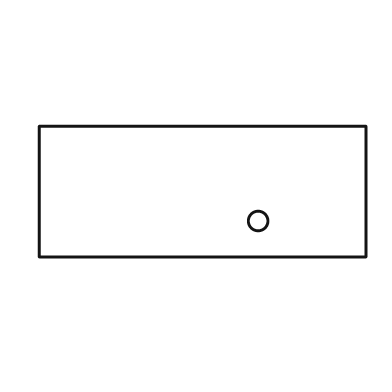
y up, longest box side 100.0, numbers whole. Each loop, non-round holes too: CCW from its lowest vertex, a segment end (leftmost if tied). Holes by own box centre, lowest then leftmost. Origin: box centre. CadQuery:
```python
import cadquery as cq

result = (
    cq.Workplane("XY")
    .moveTo(-50.0, -20.0)
    .lineTo(50.0, -20.0)
    .lineTo(50.0, 20.0)
    .lineTo(-50.0, 20.0)
    .close()
    .moveTo(17.0, -9.0)
    .circle(3.0)
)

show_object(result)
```